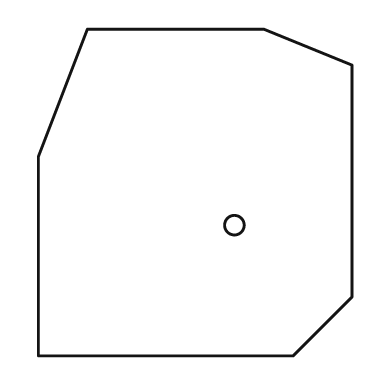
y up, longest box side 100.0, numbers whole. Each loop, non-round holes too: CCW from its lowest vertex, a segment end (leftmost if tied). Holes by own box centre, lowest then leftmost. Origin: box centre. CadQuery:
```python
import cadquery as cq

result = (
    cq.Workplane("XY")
    .moveTo(-48.0, -50.0)
    .lineTo(30.0, -50.0)
    .lineTo(48.0, -32.0)
    .lineTo(48.0, 39.0)
    .lineTo(21.0, 50.0)
    .lineTo(-33.0, 50.0)
    .lineTo(-48.0, 11.0)
    .close()
    .moveTo(12.0, -10.0)
    .circle(3.0)
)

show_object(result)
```